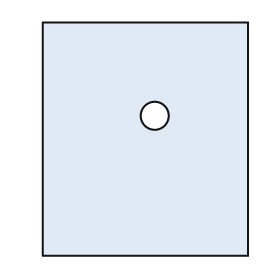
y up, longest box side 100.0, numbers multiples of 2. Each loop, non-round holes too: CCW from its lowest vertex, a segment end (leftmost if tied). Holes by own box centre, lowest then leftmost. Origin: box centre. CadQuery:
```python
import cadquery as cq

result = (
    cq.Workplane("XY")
    .moveTo(-44.0, -50.0)
    .lineTo(44.0, -50.0)
    .lineTo(44.0, 50.0)
    .lineTo(-44.0, 50.0)
    .close()
    .moveTo(4.0, 10.0)
    .circle(6.0)
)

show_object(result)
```